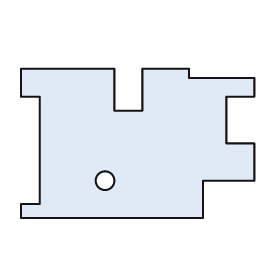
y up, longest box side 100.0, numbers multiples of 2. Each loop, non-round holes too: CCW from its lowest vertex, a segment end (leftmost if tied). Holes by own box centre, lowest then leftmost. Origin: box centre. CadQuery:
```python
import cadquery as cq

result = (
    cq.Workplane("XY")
    .moveTo(-50.0, -32.0)
    .lineTo(28.0, -32.0)
    .lineTo(28.0, -16.0)
    .lineTo(50.0, -16.0)
    .lineTo(50.0, 0.0)
    .lineTo(38.0, 0.0)
    .lineTo(38.0, 20.0)
    .lineTo(50.0, 20.0)
    .lineTo(50.0, 28.0)
    .lineTo(22.0, 28.0)
    .lineTo(22.0, 32.0)
    .lineTo(2.0, 32.0)
    .lineTo(2.0, 14.0)
    .lineTo(-10.0, 14.0)
    .lineTo(-10.0, 32.0)
    .lineTo(-50.0, 32.0)
    .lineTo(-50.0, 20.0)
    .lineTo(-42.0, 20.0)
    .lineTo(-42.0, -26.0)
    .lineTo(-50.0, -26.0)
    .close()
    .moveTo(-14.0, -16.0)
    .circle(4.0)
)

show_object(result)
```